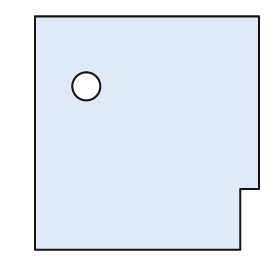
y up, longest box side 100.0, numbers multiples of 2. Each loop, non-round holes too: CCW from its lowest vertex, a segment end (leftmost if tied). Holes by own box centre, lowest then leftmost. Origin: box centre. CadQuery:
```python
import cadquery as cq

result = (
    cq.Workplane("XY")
    .moveTo(-48.0, -50.0)
    .lineTo(40.0, -50.0)
    .lineTo(40.0, -24.0)
    .lineTo(48.0, -24.0)
    .lineTo(48.0, 50.0)
    .lineTo(-48.0, 50.0)
    .close()
    .moveTo(-26.0, 20.0)
    .circle(6.0)
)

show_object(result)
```